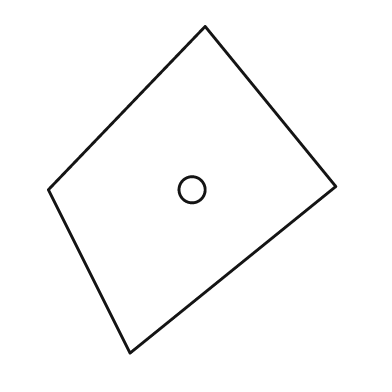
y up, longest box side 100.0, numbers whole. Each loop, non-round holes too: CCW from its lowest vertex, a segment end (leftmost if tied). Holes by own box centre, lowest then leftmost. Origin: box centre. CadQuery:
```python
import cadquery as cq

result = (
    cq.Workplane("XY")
    .moveTo(-19.0, -50.0)
    .lineTo(44.0, 1.0)
    .lineTo(4.0, 50.0)
    .lineTo(-44.0, 0.0)
    .close()
    .moveTo(0.0, 0.0)
    .circle(4.0)
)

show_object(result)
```